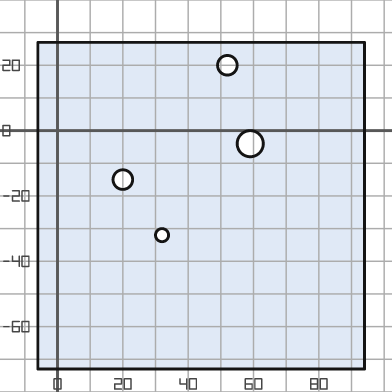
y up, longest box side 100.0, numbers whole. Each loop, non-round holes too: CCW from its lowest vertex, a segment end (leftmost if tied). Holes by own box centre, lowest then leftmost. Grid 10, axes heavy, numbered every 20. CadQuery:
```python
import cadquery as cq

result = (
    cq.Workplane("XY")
    .moveTo(-6.0, -73.0)
    .lineTo(94.0, -73.0)
    .lineTo(94.0, 27.0)
    .lineTo(-6.0, 27.0)
    .close()
    .moveTo(32.0, -32.0)
    .circle(2.0)
    .moveTo(20.0, -15.0)
    .circle(3.0)
    .moveTo(59.0, -4.0)
    .circle(4.0)
    .moveTo(52.0, 20.0)
    .circle(3.0)
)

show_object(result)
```